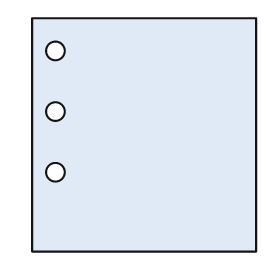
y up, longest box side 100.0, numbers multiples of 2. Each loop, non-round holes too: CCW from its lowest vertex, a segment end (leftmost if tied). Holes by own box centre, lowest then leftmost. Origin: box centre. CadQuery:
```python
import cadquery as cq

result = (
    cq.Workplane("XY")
    .moveTo(-48.0, -50.0)
    .lineTo(48.0, -50.0)
    .lineTo(48.0, 50.0)
    .lineTo(-48.0, 50.0)
    .close()
    .moveTo(-38.0, -16.0)
    .circle(4.0)
    .moveTo(-38.0, 10.0)
    .circle(4.0)
    .moveTo(-38.0, 36.0)
    .circle(4.0)
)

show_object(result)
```